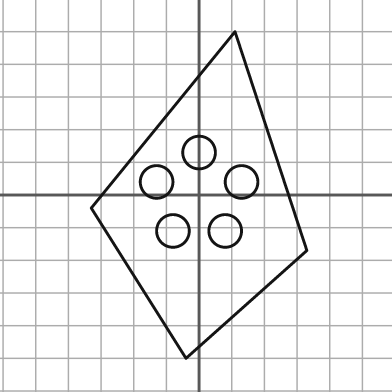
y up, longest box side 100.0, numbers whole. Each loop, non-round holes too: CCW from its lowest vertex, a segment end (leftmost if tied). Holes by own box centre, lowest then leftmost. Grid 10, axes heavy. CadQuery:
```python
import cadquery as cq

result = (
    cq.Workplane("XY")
    .moveTo(-4.0, -50.0)
    .lineTo(33.0, -17.0)
    .lineTo(11.0, 50.0)
    .lineTo(-33.0, -4.0)
    .close()
    .moveTo(-8.0, -11.0)
    .circle(5.0)
    .moveTo(8.0, -11.0)
    .circle(5.0)
    .moveTo(-13.0, 4.0)
    .circle(5.0)
    .moveTo(13.0, 4.0)
    .circle(5.0)
    .moveTo(0.0, 13.0)
    .circle(5.0)
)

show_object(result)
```